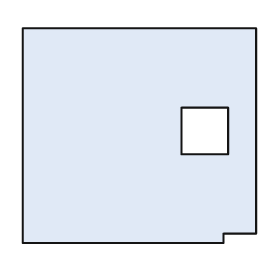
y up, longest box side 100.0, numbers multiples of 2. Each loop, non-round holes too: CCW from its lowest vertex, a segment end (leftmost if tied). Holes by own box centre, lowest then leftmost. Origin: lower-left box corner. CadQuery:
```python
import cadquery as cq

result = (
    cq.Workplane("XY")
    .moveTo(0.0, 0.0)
    .lineTo(86.0, 0.0)
    .lineTo(86.0, 4.0)
    .lineTo(100.0, 4.0)
    .lineTo(100.0, 92.0)
    .lineTo(0.0, 92.0)
    .close()
    .moveTo(68.0, 38.0)
    .lineTo(88.0, 38.0)
    .lineTo(88.0, 58.0)
    .lineTo(68.0, 58.0)
    .close()
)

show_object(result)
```